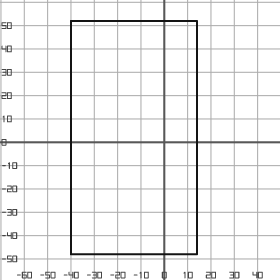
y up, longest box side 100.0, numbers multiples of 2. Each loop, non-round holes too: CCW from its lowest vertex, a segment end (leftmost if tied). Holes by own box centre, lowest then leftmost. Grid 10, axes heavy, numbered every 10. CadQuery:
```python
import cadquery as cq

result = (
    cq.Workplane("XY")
    .moveTo(-40.0, -48.0)
    .lineTo(14.0, -48.0)
    .lineTo(14.0, 52.0)
    .lineTo(-40.0, 52.0)
    .close()
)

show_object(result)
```